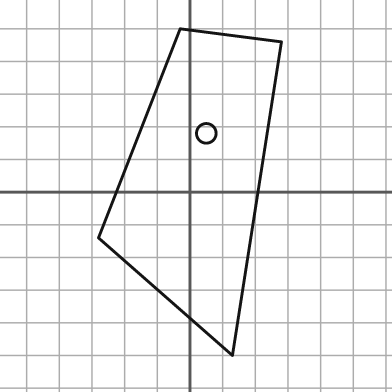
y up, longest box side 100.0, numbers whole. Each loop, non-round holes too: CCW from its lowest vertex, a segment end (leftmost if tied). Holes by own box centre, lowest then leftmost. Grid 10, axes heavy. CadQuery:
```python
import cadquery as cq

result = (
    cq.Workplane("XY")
    .moveTo(13.0, -50.0)
    .lineTo(28.0, 46.0)
    .lineTo(-3.0, 50.0)
    .lineTo(-28.0, -14.0)
    .close()
    .moveTo(5.0, 18.0)
    .circle(3.0)
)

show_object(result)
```